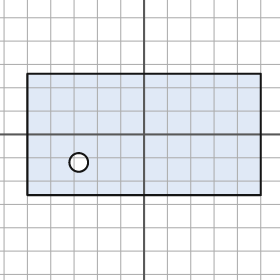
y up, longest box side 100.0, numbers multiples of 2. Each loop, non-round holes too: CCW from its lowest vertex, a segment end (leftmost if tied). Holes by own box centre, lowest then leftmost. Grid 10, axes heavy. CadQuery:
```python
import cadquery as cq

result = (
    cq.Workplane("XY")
    .moveTo(-50.0, -26.0)
    .lineTo(50.0, -26.0)
    .lineTo(50.0, 26.0)
    .lineTo(-50.0, 26.0)
    .close()
    .moveTo(-28.0, -12.0)
    .circle(4.0)
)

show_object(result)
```